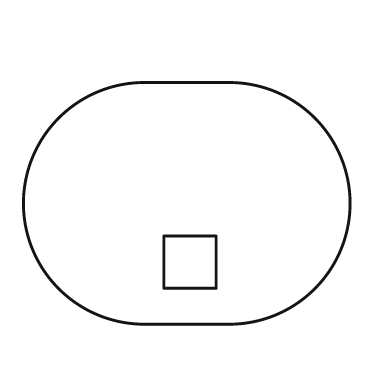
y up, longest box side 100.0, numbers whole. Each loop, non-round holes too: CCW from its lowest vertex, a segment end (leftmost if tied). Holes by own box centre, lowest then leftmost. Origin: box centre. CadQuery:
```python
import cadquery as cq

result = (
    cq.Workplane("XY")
    .moveTo(-13.0, -37.0)
    .lineTo(13.0, -37.0)
    .threePointArc((50.0, 0.0), (13.0, 37.0))
    .lineTo(-13.0, 37.0)
    .threePointArc((-50.0, 0.0), (-13.0, -37.0))
    .close()
    .moveTo(-7.0, -26.0)
    .lineTo(9.0, -26.0)
    .lineTo(9.0, -10.0)
    .lineTo(-7.0, -10.0)
    .close()
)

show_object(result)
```